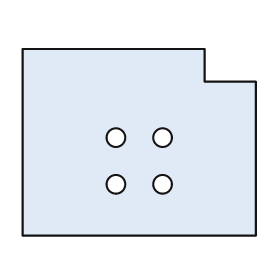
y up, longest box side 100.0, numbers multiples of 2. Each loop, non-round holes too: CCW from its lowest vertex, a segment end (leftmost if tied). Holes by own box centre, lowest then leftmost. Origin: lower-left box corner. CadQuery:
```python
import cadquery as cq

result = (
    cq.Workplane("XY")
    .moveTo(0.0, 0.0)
    .lineTo(100.0, 0.0)
    .lineTo(100.0, 66.0)
    .lineTo(78.0, 66.0)
    .lineTo(78.0, 80.0)
    .lineTo(0.0, 80.0)
    .close()
    .moveTo(40.0, 22.0)
    .circle(4.0)
    .moveTo(60.0, 22.0)
    .circle(4.0)
    .moveTo(40.0, 42.0)
    .circle(4.0)
    .moveTo(60.0, 42.0)
    .circle(4.0)
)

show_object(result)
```